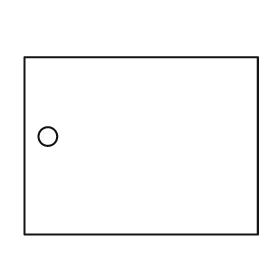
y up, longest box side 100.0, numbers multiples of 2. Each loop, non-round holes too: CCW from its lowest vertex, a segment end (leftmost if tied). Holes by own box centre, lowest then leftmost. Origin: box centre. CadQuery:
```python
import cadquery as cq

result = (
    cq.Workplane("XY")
    .moveTo(-50.0, -38.0)
    .lineTo(50.0, -38.0)
    .lineTo(50.0, 38.0)
    .lineTo(-50.0, 38.0)
    .close()
    .moveTo(-40.0, 4.0)
    .circle(4.0)
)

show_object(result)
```